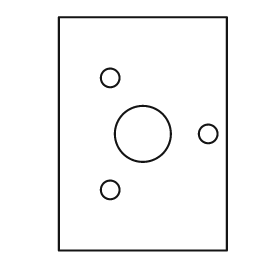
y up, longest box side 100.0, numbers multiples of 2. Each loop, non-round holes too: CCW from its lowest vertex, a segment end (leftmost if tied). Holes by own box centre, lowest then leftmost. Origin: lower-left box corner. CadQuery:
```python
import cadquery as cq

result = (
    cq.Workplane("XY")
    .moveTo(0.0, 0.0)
    .lineTo(72.0, 0.0)
    .lineTo(72.0, 100.0)
    .lineTo(0.0, 100.0)
    .close()
    .moveTo(22.0, 26.0)
    .circle(4.0)
    .moveTo(36.0, 50.0)
    .circle(12.0)
    .moveTo(64.0, 50.0)
    .circle(4.0)
    .moveTo(22.0, 74.0)
    .circle(4.0)
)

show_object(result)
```